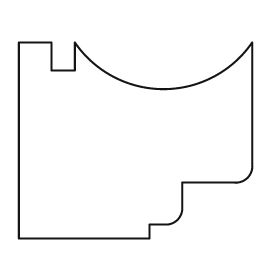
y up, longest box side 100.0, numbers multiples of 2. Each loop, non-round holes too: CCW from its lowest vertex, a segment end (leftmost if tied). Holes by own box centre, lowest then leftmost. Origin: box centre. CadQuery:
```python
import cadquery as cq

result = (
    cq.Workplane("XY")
    .moveTo(-50.0, -42.0)
    .lineTo(6.0, -42.0)
    .lineTo(6.0, -36.0)
    .lineTo(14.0, -36.0)
    .threePointArc((18.0, -34.0), (20.0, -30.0))
    .lineTo(20.0, -18.0)
    .lineTo(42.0, -18.0)
    .threePointArc((48.0, -16.0), (50.0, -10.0))
    .lineTo(50.0, 42.0)
    .threePointArc((12.0, 22.0), (-26.0, 42.0))
    .lineTo(-26.0, 30.0)
    .lineTo(-36.0, 30.0)
    .lineTo(-36.0, 42.0)
    .lineTo(-50.0, 42.0)
    .close()
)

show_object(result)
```